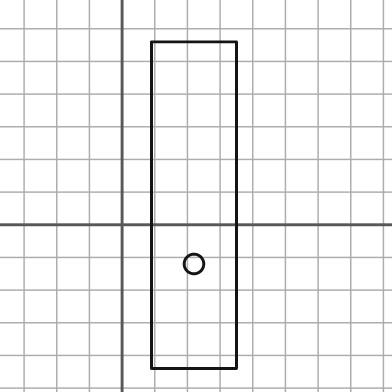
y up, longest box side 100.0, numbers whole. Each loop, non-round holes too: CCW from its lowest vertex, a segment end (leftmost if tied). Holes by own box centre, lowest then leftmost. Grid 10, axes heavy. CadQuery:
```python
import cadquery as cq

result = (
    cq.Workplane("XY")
    .moveTo(9.0, -44.0)
    .lineTo(35.0, -44.0)
    .lineTo(35.0, 56.0)
    .lineTo(9.0, 56.0)
    .close()
    .moveTo(22.0, -12.0)
    .circle(3.0)
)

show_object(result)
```